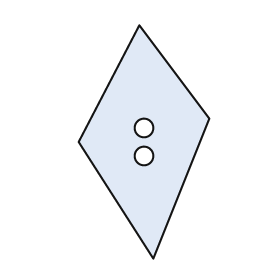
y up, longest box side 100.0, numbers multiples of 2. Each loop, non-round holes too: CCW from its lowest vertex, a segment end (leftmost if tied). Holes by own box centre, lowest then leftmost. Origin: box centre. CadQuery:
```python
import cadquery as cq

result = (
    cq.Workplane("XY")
    .moveTo(4.0, -50.0)
    .lineTo(28.0, 10.0)
    .lineTo(-2.0, 50.0)
    .lineTo(-28.0, 0.0)
    .close()
    .moveTo(0.0, -6.0)
    .circle(4.0)
    .moveTo(0.0, 6.0)
    .circle(4.0)
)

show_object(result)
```